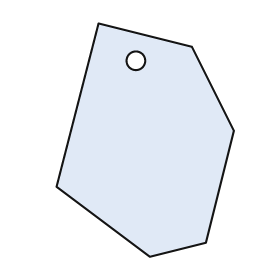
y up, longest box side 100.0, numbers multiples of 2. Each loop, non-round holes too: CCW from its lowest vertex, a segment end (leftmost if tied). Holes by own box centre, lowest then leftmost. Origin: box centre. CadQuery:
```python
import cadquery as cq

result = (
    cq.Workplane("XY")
    .moveTo(2.0, -50.0)
    .lineTo(26.0, -44.0)
    .lineTo(38.0, 4.0)
    .lineTo(20.0, 40.0)
    .lineTo(-20.0, 50.0)
    .lineTo(-38.0, -20.0)
    .close()
    .moveTo(-4.0, 34.0)
    .circle(4.0)
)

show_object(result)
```